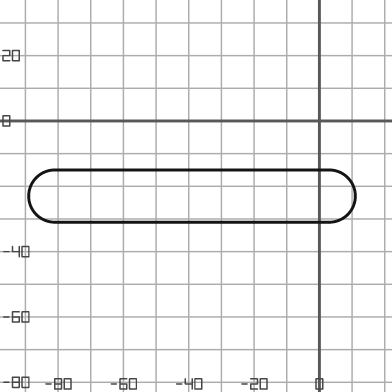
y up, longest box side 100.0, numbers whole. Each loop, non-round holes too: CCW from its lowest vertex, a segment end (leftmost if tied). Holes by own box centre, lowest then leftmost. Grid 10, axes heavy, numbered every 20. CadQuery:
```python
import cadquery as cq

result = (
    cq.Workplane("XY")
    .moveTo(-81.0, -31.0)
    .lineTo(3.0, -31.0)
    .threePointArc((11.0, -23.0), (3.0, -15.0))
    .lineTo(-81.0, -15.0)
    .threePointArc((-89.0, -23.0), (-81.0, -31.0))
    .close()
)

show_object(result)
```